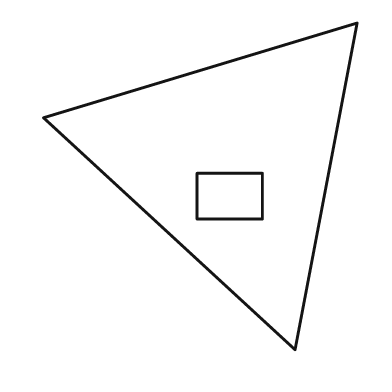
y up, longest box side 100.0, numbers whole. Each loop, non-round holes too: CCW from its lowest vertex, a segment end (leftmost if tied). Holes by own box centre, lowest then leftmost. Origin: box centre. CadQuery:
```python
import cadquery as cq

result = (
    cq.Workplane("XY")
    .moveTo(29.0, -50.0)
    .lineTo(48.0, 50.0)
    .lineTo(-48.0, 21.0)
    .close()
    .moveTo(-1.0, -10.0)
    .lineTo(19.0, -10.0)
    .lineTo(19.0, 4.0)
    .lineTo(-1.0, 4.0)
    .close()
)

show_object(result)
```